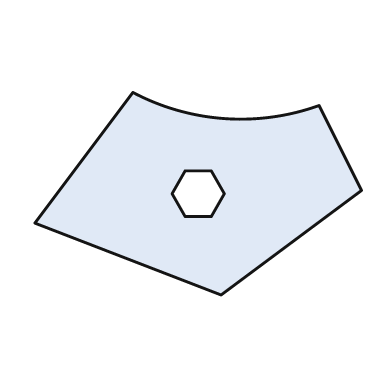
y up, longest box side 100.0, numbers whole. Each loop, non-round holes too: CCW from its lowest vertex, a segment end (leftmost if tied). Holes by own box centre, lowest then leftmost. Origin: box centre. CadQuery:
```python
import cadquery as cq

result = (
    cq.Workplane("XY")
    .moveTo(7.0, -31.0)
    .lineTo(50.0, 1.0)
    .lineTo(37.0, 27.0)
    .threePointArc((8.0, 23.0), (-20.0, 31.0))
    .lineTo(-50.0, -9.0)
    .close()
    .moveTo(-4.0, -7.0)
    .lineTo(4.0, -7.0)
    .lineTo(8.0, 0.0)
    .lineTo(4.0, 7.0)
    .lineTo(-4.0, 7.0)
    .lineTo(-8.0, 0.0)
    .close()
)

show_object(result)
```